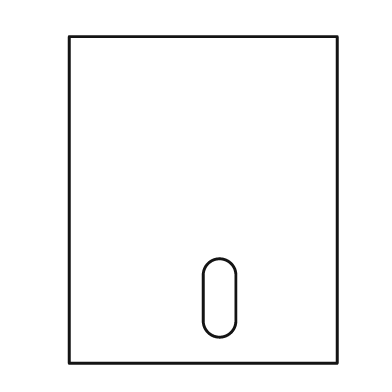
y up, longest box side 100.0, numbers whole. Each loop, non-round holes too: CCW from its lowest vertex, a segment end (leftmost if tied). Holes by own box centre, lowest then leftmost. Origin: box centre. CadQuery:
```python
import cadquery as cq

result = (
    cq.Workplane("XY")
    .moveTo(-41.0, -50.0)
    .lineTo(41.0, -50.0)
    .lineTo(41.0, 50.0)
    .lineTo(-41.0, 50.0)
    .close()
    .moveTo(0.0, -37.0)
    .threePointArc((5.0, -42.0), (10.0, -37.0))
    .lineTo(10.0, -23.0)
    .threePointArc((5.0, -18.0), (0.0, -23.0))
    .close()
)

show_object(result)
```